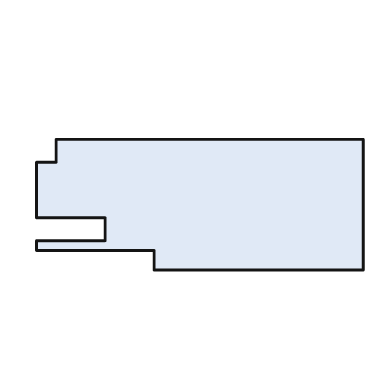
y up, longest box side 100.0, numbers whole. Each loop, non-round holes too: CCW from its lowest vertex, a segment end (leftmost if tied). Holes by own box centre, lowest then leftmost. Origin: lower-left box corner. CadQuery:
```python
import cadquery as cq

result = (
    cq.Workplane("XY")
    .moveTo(36.0, 0.0)
    .lineTo(100.0, 0.0)
    .lineTo(100.0, 40.0)
    .lineTo(6.0, 40.0)
    .lineTo(6.0, 33.0)
    .lineTo(0.0, 33.0)
    .lineTo(0.0, 16.0)
    .lineTo(21.0, 16.0)
    .lineTo(21.0, 9.0)
    .lineTo(0.0, 9.0)
    .lineTo(0.0, 6.0)
    .lineTo(36.0, 6.0)
    .close()
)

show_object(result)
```